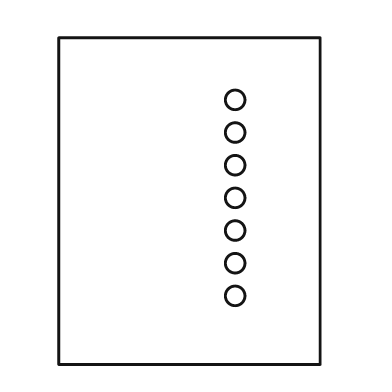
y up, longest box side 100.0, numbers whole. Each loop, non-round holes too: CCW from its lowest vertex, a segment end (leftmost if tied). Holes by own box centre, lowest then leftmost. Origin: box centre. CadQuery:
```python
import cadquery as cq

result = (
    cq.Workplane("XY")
    .moveTo(-40.0, -50.0)
    .lineTo(40.0, -50.0)
    .lineTo(40.0, 50.0)
    .lineTo(-40.0, 50.0)
    .close()
    .moveTo(14.0, -29.0)
    .circle(3.0)
    .moveTo(14.0, -19.0)
    .circle(3.0)
    .moveTo(14.0, -9.0)
    .circle(3.0)
    .moveTo(14.0, 1.0)
    .circle(3.0)
    .moveTo(14.0, 11.0)
    .circle(3.0)
    .moveTo(14.0, 21.0)
    .circle(3.0)
    .moveTo(14.0, 31.0)
    .circle(3.0)
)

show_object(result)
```